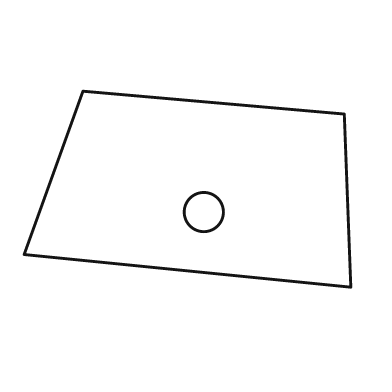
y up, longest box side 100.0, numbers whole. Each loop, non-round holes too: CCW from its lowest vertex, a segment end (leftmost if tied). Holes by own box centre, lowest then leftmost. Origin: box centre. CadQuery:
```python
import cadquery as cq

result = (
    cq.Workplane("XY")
    .moveTo(50.0, -30.0)
    .lineTo(48.0, 23.0)
    .lineTo(-32.0, 30.0)
    .lineTo(-50.0, -20.0)
    .close()
    .moveTo(5.0, -7.0)
    .circle(6.0)
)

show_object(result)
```